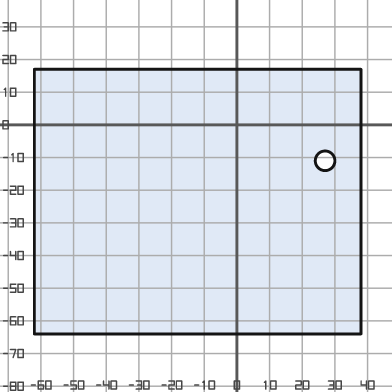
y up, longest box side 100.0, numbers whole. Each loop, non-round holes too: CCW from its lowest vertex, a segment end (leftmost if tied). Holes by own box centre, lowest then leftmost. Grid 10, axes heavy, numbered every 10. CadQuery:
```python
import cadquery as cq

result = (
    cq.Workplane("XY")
    .moveTo(-62.0, -64.0)
    .lineTo(38.0, -64.0)
    .lineTo(38.0, 17.0)
    .lineTo(-62.0, 17.0)
    .close()
    .moveTo(27.0, -11.0)
    .circle(3.0)
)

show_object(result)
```